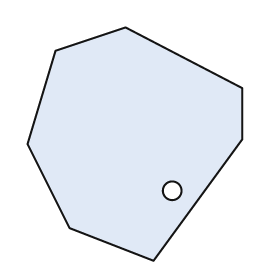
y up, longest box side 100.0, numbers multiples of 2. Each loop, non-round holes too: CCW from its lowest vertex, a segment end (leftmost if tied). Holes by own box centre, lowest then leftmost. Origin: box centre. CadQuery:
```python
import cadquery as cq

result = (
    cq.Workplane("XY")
    .moveTo(8.0, -50.0)
    .lineTo(46.0, 2.0)
    .lineTo(46.0, 24.0)
    .lineTo(-4.0, 50.0)
    .lineTo(-34.0, 40.0)
    .lineTo(-46.0, 0.0)
    .lineTo(-28.0, -36.0)
    .close()
    .moveTo(16.0, -20.0)
    .circle(4.0)
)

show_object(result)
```